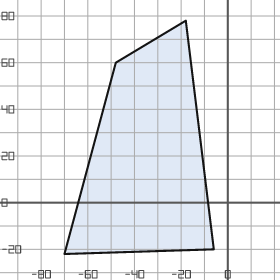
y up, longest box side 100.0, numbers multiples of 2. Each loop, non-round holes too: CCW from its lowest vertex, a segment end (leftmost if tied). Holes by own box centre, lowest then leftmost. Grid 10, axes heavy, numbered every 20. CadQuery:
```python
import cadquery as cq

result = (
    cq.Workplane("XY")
    .moveTo(-70.0, -22.0)
    .lineTo(-6.0, -20.0)
    .lineTo(-18.0, 78.0)
    .lineTo(-48.0, 60.0)
    .close()
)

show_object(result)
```